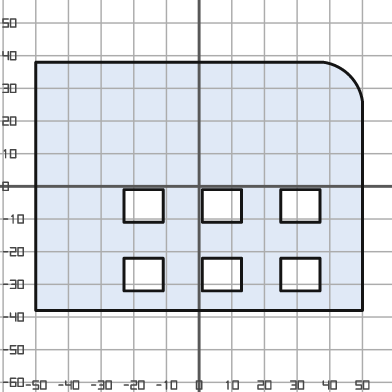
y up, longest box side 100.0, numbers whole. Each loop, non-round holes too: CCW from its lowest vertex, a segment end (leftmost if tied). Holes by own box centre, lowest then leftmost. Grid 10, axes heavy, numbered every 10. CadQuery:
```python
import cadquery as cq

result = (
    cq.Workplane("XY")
    .moveTo(-50.0, -38.0)
    .lineTo(50.0, -38.0)
    .lineTo(50.0, 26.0)
    .threePointArc((46.0, 34.0), (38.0, 38.0))
    .lineTo(-50.0, 38.0)
    .close()
    .moveTo(-23.0, -32.0)
    .lineTo(-11.0, -32.0)
    .lineTo(-11.0, -22.0)
    .lineTo(-23.0, -22.0)
    .close()
    .moveTo(1.0, -32.0)
    .lineTo(13.0, -32.0)
    .lineTo(13.0, -22.0)
    .lineTo(1.0, -22.0)
    .close()
    .moveTo(25.0, -32.0)
    .lineTo(37.0, -32.0)
    .lineTo(37.0, -22.0)
    .lineTo(25.0, -22.0)
    .close()
    .moveTo(-23.0, -11.0)
    .lineTo(-11.0, -11.0)
    .lineTo(-11.0, -1.0)
    .lineTo(-23.0, -1.0)
    .close()
    .moveTo(1.0, -11.0)
    .lineTo(13.0, -11.0)
    .lineTo(13.0, -1.0)
    .lineTo(1.0, -1.0)
    .close()
    .moveTo(25.0, -11.0)
    .lineTo(37.0, -11.0)
    .lineTo(37.0, -1.0)
    .lineTo(25.0, -1.0)
    .close()
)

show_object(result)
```